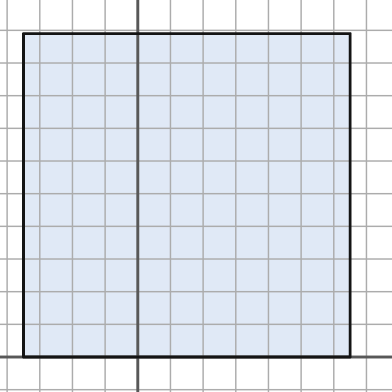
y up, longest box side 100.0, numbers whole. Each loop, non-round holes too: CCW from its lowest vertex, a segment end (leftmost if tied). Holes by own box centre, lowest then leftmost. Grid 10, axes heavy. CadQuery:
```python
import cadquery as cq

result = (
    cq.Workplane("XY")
    .moveTo(-35.0, 0.0)
    .lineTo(65.0, 0.0)
    .lineTo(65.0, 99.0)
    .lineTo(-35.0, 99.0)
    .close()
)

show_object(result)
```